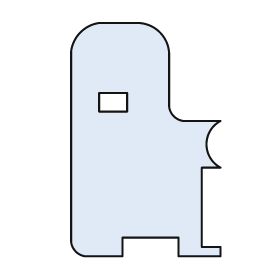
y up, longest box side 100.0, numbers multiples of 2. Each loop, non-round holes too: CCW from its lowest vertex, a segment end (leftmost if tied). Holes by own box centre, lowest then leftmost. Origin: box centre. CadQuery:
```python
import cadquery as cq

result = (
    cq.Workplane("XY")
    .moveTo(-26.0, -50.0)
    .lineTo(-10.0, -50.0)
    .lineTo(-10.0, -42.0)
    .lineTo(14.0, -42.0)
    .lineTo(14.0, -50.0)
    .lineTo(32.0, -50.0)
    .lineTo(32.0, -46.0)
    .lineTo(24.0, -46.0)
    .lineTo(24.0, -12.0)
    .lineTo(32.0, -12.0)
    .threePointArc((26.0, -2.0), (32.0, 8.0))
    .lineTo(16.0, 8.0)
    .threePointArc((12.0, 10.0), (10.0, 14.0))
    .lineTo(10.0, 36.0)
    .threePointArc((6.0, 46.0), (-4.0, 50.0))
    .lineTo(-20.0, 50.0)
    .threePointArc((-28.0, 46.0), (-32.0, 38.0))
    .lineTo(-32.0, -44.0)
    .threePointArc((-30.0, -48.0), (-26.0, -50.0))
    .close()
    .moveTo(-20.0, 12.0)
    .lineTo(-8.0, 12.0)
    .lineTo(-8.0, 20.0)
    .lineTo(-20.0, 20.0)
    .close()
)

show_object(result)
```